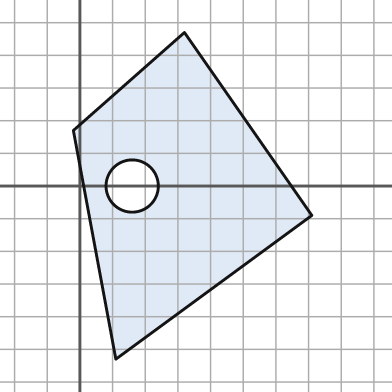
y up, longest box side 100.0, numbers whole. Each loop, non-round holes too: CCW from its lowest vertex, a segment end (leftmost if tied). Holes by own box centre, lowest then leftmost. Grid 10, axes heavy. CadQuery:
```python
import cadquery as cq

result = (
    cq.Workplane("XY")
    .moveTo(11.0, -53.0)
    .lineTo(71.0, -9.0)
    .lineTo(32.0, 47.0)
    .lineTo(-2.0, 17.0)
    .close()
    .moveTo(16.0, 0.0)
    .circle(8.0)
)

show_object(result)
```